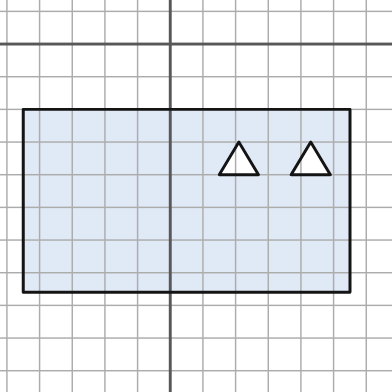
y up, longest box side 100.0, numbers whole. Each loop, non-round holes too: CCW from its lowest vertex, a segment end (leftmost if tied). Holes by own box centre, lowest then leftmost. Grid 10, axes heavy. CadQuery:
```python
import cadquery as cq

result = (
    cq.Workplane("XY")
    .moveTo(-45.0, -76.0)
    .lineTo(55.0, -76.0)
    .lineTo(55.0, -20.0)
    .lineTo(-45.0, -20.0)
    .close()
    .moveTo(15.0, -40.0)
    .lineTo(27.0, -40.0)
    .lineTo(21.0, -30.0)
    .close()
    .moveTo(37.0, -40.0)
    .lineTo(49.0, -40.0)
    .lineTo(43.0, -30.0)
    .close()
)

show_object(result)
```